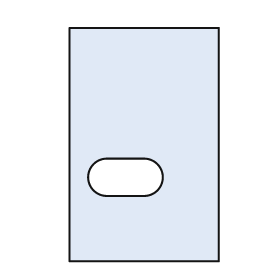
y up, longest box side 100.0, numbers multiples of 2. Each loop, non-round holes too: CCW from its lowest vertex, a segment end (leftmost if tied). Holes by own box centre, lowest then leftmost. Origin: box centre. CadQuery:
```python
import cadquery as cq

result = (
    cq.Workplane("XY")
    .moveTo(-32.0, -50.0)
    .lineTo(32.0, -50.0)
    .lineTo(32.0, 50.0)
    .lineTo(-32.0, 50.0)
    .close()
    .moveTo(-16.0, -22.0)
    .lineTo(0.0, -22.0)
    .threePointArc((8.0, -14.0), (0.0, -6.0))
    .lineTo(-16.0, -6.0)
    .threePointArc((-24.0, -14.0), (-16.0, -22.0))
    .close()
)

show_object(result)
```